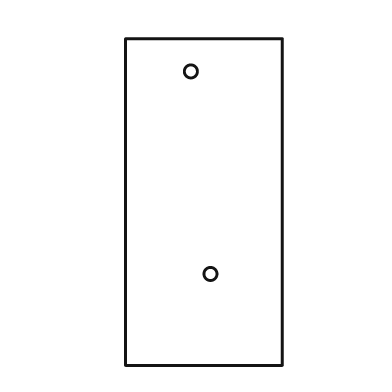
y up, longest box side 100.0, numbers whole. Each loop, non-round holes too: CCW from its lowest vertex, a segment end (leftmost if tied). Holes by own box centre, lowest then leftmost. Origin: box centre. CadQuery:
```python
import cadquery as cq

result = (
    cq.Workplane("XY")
    .moveTo(-24.0, -50.0)
    .lineTo(24.0, -50.0)
    .lineTo(24.0, 50.0)
    .lineTo(-24.0, 50.0)
    .close()
    .moveTo(2.0, -22.0)
    .circle(2.0)
    .moveTo(-4.0, 40.0)
    .circle(2.0)
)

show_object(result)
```